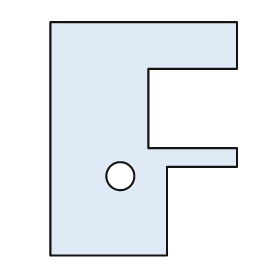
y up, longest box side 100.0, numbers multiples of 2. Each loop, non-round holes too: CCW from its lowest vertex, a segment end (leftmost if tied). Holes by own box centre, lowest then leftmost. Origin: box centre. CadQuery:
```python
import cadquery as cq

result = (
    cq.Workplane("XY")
    .moveTo(-40.0, -50.0)
    .lineTo(10.0, -50.0)
    .lineTo(10.0, -12.0)
    .lineTo(40.0, -12.0)
    .lineTo(40.0, -4.0)
    .lineTo(2.0, -4.0)
    .lineTo(2.0, 30.0)
    .lineTo(40.0, 30.0)
    .lineTo(40.0, 50.0)
    .lineTo(-40.0, 50.0)
    .close()
    .moveTo(-10.0, -16.0)
    .circle(6.0)
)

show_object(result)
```